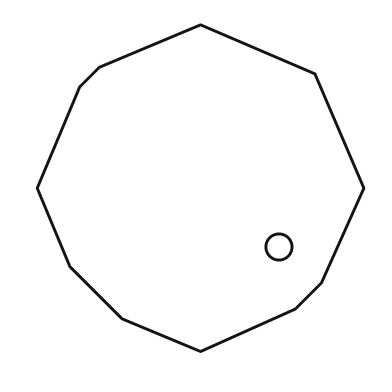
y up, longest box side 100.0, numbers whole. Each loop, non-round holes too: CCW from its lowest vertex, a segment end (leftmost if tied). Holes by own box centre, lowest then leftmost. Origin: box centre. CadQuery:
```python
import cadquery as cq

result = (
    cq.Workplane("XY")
    .moveTo(0.0, -50.0)
    .lineTo(29.0, -37.0)
    .lineTo(37.0, -29.0)
    .lineTo(50.0, 0.0)
    .lineTo(35.0, 35.0)
    .lineTo(0.0, 50.0)
    .lineTo(-31.0, 37.0)
    .lineTo(-37.0, 31.0)
    .lineTo(-50.0, 0.0)
    .lineTo(-40.0, -24.0)
    .lineTo(-24.0, -40.0)
    .close()
    .moveTo(24.0, -18.0)
    .circle(4.0)
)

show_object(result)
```